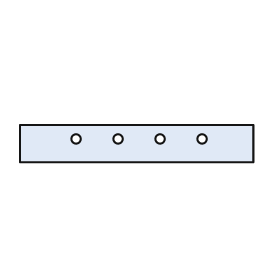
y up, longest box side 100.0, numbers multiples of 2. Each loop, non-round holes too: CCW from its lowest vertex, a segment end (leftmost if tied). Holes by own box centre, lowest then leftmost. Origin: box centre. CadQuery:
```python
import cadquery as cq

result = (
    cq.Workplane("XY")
    .moveTo(-50.0, -8.0)
    .lineTo(50.0, -8.0)
    .lineTo(50.0, 8.0)
    .lineTo(-50.0, 8.0)
    .close()
    .moveTo(-26.0, 2.0)
    .circle(2.0)
    .moveTo(-8.0, 2.0)
    .circle(2.0)
    .moveTo(10.0, 2.0)
    .circle(2.0)
    .moveTo(28.0, 2.0)
    .circle(2.0)
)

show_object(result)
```